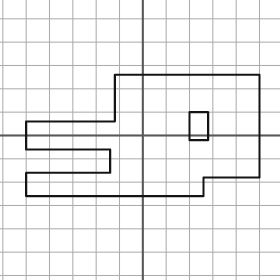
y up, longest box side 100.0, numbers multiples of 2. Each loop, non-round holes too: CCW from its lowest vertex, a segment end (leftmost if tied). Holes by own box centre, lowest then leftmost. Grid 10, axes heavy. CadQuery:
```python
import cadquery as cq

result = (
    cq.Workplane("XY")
    .moveTo(-50.0, -26.0)
    .lineTo(26.0, -26.0)
    .lineTo(26.0, -18.0)
    .lineTo(50.0, -18.0)
    .lineTo(50.0, 26.0)
    .lineTo(-12.0, 26.0)
    .lineTo(-12.0, 6.0)
    .lineTo(-50.0, 6.0)
    .lineTo(-50.0, -6.0)
    .lineTo(-14.0, -6.0)
    .lineTo(-14.0, -16.0)
    .lineTo(-50.0, -16.0)
    .close()
    .moveTo(20.0, -2.0)
    .lineTo(28.0, -2.0)
    .lineTo(28.0, 10.0)
    .lineTo(20.0, 10.0)
    .close()
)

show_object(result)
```